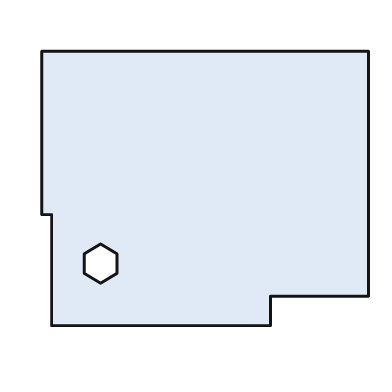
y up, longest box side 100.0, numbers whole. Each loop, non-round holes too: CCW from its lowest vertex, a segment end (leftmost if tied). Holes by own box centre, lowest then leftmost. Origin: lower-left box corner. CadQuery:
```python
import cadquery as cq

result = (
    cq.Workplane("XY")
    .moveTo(3.0, 0.0)
    .lineTo(70.0, 0.0)
    .lineTo(70.0, 9.0)
    .lineTo(100.0, 9.0)
    .lineTo(100.0, 84.0)
    .lineTo(0.0, 84.0)
    .lineTo(0.0, 34.0)
    .lineTo(3.0, 34.0)
    .close()
    .moveTo(18.0, 13.0)
    .lineTo(23.0, 16.0)
    .lineTo(23.0, 22.0)
    .lineTo(18.0, 25.0)
    .lineTo(13.0, 22.0)
    .lineTo(13.0, 16.0)
    .close()
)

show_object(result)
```